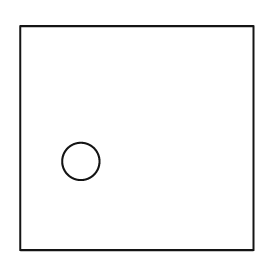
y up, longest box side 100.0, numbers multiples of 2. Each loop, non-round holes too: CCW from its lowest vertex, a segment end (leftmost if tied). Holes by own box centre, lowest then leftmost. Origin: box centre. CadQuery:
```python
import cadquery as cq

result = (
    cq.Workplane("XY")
    .moveTo(-50.0, -48.0)
    .lineTo(50.0, -48.0)
    .lineTo(50.0, 48.0)
    .lineTo(-50.0, 48.0)
    .close()
    .moveTo(-24.0, -10.0)
    .circle(8.0)
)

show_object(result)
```